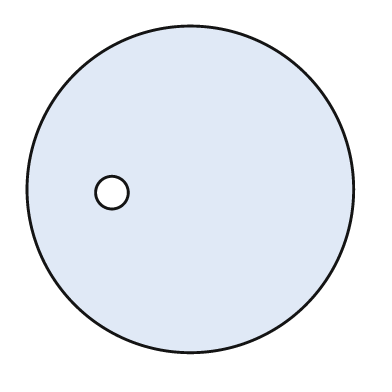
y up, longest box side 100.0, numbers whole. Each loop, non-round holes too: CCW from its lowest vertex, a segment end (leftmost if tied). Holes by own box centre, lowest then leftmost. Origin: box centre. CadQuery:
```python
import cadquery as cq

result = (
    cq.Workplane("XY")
    .moveTo(0.0, 0.0)
    .circle(50.0)
    .moveTo(-24.0, -1.0)
    .circle(5.0)
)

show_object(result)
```